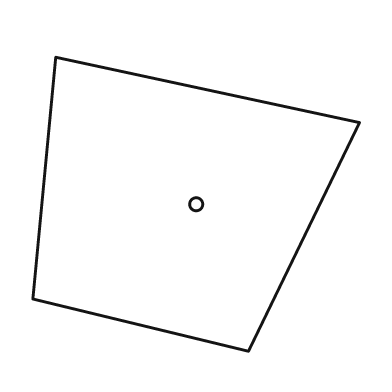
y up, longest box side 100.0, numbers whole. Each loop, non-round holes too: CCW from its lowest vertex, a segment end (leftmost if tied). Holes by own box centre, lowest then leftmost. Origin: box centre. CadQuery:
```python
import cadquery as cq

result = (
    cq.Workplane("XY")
    .moveTo(16.0, -45.0)
    .lineTo(50.0, 25.0)
    .lineTo(-43.0, 45.0)
    .lineTo(-50.0, -29.0)
    .close()
    .moveTo(0.0, 0.0)
    .circle(2.0)
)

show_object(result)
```